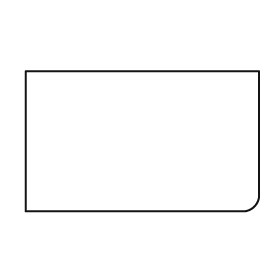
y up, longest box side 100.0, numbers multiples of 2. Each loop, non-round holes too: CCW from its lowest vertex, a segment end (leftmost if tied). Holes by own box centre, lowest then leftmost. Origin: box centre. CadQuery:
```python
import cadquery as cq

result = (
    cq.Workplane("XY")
    .moveTo(-50.0, -30.0)
    .lineTo(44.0, -30.0)
    .threePointArc((48.0, -28.0), (50.0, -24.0))
    .lineTo(50.0, 30.0)
    .lineTo(-50.0, 30.0)
    .close()
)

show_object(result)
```